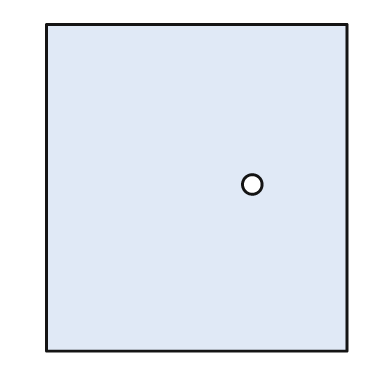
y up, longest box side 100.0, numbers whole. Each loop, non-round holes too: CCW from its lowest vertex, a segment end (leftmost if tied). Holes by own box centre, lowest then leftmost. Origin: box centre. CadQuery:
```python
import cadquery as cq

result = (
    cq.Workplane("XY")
    .moveTo(-46.0, -50.0)
    .lineTo(46.0, -50.0)
    .lineTo(46.0, 50.0)
    .lineTo(-46.0, 50.0)
    .close()
    .moveTo(17.0, 1.0)
    .circle(3.0)
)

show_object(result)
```